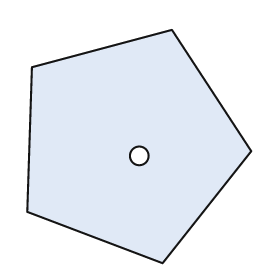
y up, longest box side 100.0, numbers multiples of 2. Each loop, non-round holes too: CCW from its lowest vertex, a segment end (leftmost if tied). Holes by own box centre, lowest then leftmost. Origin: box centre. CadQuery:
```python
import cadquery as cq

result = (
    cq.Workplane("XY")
    .moveTo(10.0, -50.0)
    .lineTo(48.0, -2.0)
    .lineTo(14.0, 50.0)
    .lineTo(-46.0, 34.0)
    .lineTo(-48.0, -28.0)
    .close()
    .moveTo(0.0, -4.0)
    .circle(4.0)
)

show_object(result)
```